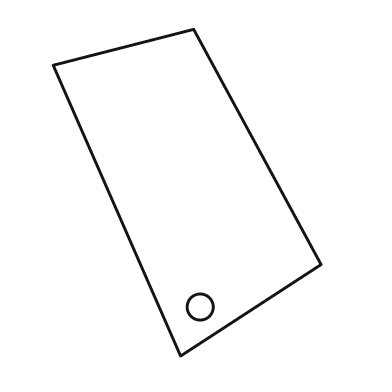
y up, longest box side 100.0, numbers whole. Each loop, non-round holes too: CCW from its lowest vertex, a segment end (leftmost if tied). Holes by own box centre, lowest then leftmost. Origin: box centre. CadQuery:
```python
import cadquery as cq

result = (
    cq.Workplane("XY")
    .moveTo(-2.0, -50.0)
    .lineTo(41.0, -22.0)
    .lineTo(2.0, 50.0)
    .lineTo(-41.0, 39.0)
    .close()
    .moveTo(4.0, -35.0)
    .circle(4.0)
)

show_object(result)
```